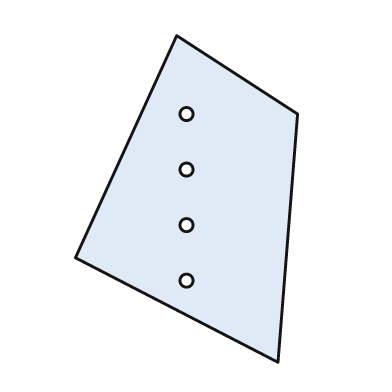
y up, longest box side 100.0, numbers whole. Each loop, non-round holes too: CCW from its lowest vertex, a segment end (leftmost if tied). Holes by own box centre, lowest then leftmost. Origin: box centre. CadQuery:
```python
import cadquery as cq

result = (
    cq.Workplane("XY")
    .moveTo(28.0, -50.0)
    .lineTo(34.0, 26.0)
    .lineTo(-3.0, 50.0)
    .lineTo(-34.0, -18.0)
    .close()
    .moveTo(0.0, -25.0)
    .circle(2.0)
    .moveTo(0.0, -8.0)
    .circle(2.0)
    .moveTo(0.0, 9.0)
    .circle(2.0)
    .moveTo(0.0, 26.0)
    .circle(2.0)
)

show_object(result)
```